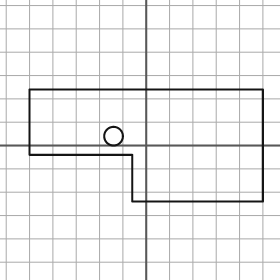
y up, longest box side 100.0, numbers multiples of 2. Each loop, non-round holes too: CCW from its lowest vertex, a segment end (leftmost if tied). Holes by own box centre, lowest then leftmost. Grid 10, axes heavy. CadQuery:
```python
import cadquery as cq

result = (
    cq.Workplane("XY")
    .moveTo(-6.0, -24.0)
    .lineTo(50.0, -24.0)
    .lineTo(50.0, 24.0)
    .lineTo(-50.0, 24.0)
    .lineTo(-50.0, -4.0)
    .lineTo(-6.0, -4.0)
    .close()
    .moveTo(-14.0, 4.0)
    .circle(4.0)
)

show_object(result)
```